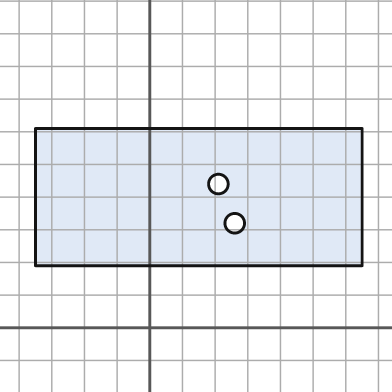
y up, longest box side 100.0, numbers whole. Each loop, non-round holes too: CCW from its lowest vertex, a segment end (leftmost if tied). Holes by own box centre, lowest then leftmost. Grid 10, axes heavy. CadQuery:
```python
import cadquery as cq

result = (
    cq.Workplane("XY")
    .moveTo(-35.0, 19.0)
    .lineTo(65.0, 19.0)
    .lineTo(65.0, 61.0)
    .lineTo(-35.0, 61.0)
    .close()
    .moveTo(26.0, 32.0)
    .circle(3.0)
    .moveTo(21.0, 44.0)
    .circle(3.0)
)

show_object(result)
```